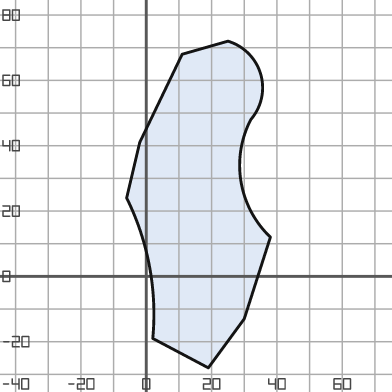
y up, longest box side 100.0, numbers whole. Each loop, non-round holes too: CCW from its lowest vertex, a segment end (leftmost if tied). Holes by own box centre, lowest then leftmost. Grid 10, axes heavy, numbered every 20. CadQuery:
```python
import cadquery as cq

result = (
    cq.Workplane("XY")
    .moveTo(19.0, -28.0)
    .lineTo(30.0, -13.0)
    .lineTo(38.0, 12.0)
    .threePointArc((29.0, 29.0), (32.0, 48.0))
    .threePointArc((35.0, 62.0), (25.0, 72.0))
    .lineTo(11.0, 68.0)
    .lineTo(-2.0, 41.0)
    .lineTo(-6.0, 24.0)
    .threePointArc((1.0, 3.0), (2.0, -19.0))
    .close()
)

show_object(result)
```